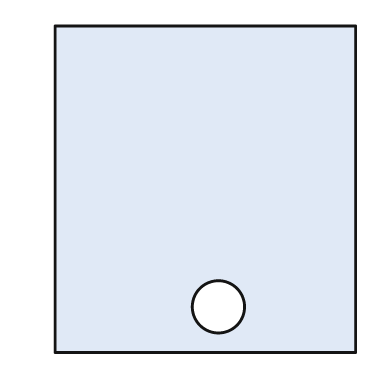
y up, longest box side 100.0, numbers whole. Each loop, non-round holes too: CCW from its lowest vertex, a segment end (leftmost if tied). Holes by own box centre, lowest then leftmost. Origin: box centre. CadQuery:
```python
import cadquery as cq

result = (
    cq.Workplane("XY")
    .moveTo(-46.0, -50.0)
    .lineTo(46.0, -50.0)
    .lineTo(46.0, 50.0)
    .lineTo(-46.0, 50.0)
    .close()
    .moveTo(4.0, -36.0)
    .circle(8.0)
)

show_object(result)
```